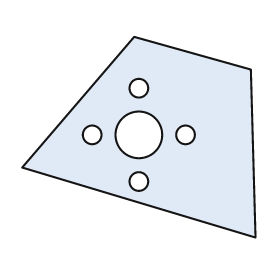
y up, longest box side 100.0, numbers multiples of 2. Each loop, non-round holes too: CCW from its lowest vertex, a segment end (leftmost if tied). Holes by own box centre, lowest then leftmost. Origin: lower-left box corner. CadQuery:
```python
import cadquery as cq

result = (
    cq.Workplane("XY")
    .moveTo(100.0, 0.0)
    .lineTo(98.0, 72.0)
    .lineTo(48.0, 86.0)
    .lineTo(0.0, 30.0)
    .close()
    .moveTo(50.0, 24.0)
    .circle(4.0)
    .moveTo(30.0, 44.0)
    .circle(4.0)
    .moveTo(50.0, 44.0)
    .circle(10.0)
    .moveTo(70.0, 44.0)
    .circle(4.0)
    .moveTo(50.0, 64.0)
    .circle(4.0)
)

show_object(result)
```